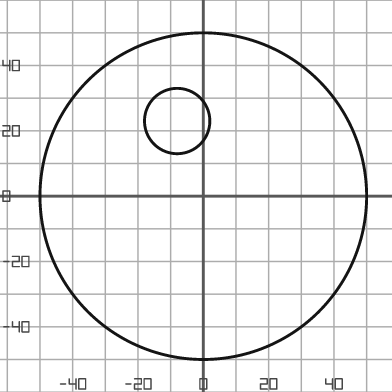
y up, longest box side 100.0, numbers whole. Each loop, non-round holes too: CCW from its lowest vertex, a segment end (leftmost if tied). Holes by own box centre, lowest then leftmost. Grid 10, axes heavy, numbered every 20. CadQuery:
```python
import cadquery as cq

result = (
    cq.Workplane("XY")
    .moveTo(0.0, 0.0)
    .circle(50.0)
    .moveTo(-8.0, 23.0)
    .circle(10.0)
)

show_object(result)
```